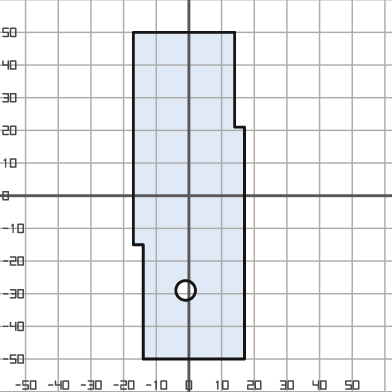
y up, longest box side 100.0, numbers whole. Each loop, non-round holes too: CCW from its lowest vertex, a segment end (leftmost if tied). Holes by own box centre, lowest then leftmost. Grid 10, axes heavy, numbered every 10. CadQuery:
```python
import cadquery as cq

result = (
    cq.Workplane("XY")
    .moveTo(-14.0, -50.0)
    .lineTo(17.0, -50.0)
    .lineTo(17.0, 21.0)
    .lineTo(14.0, 21.0)
    .lineTo(14.0, 50.0)
    .lineTo(-17.0, 50.0)
    .lineTo(-17.0, -15.0)
    .lineTo(-14.0, -15.0)
    .close()
    .moveTo(-1.0, -29.0)
    .circle(3.0)
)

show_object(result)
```